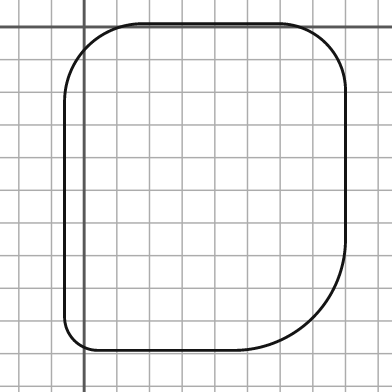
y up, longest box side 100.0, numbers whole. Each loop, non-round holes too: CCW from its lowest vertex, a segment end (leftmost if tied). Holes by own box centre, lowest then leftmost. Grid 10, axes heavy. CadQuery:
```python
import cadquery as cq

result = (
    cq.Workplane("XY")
    .moveTo(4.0, -99.0)
    .lineTo(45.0, -99.0)
    .threePointArc((70.0, -89.0), (80.0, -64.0))
    .lineTo(80.0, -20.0)
    .threePointArc((74.0, -5.0), (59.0, 1.0))
    .lineTo(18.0, 1.0)
    .threePointArc((1.0, -6.0), (-6.0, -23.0))
    .lineTo(-6.0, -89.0)
    .threePointArc((-3.0, -96.0), (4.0, -99.0))
    .close()
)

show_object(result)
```